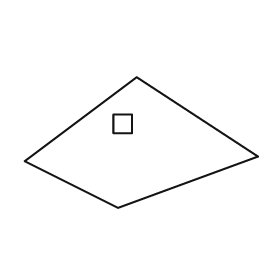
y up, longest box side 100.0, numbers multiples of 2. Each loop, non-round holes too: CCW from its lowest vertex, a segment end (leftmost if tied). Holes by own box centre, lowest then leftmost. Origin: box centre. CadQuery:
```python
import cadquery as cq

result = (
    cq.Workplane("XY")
    .moveTo(-10.0, -28.0)
    .lineTo(50.0, -6.0)
    .lineTo(-2.0, 28.0)
    .lineTo(-50.0, -8.0)
    .close()
    .moveTo(-12.0, 4.0)
    .lineTo(-4.0, 4.0)
    .lineTo(-4.0, 12.0)
    .lineTo(-12.0, 12.0)
    .close()
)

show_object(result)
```